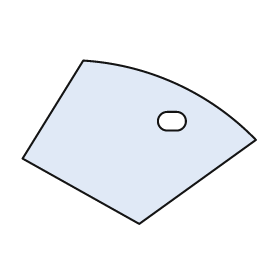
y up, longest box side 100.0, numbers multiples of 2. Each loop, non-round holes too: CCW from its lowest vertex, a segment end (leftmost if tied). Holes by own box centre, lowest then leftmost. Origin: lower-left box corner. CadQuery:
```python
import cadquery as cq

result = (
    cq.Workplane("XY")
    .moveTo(50.0, 0.0)
    .lineTo(100.0, 36.0)
    .threePointArc((66.0, 60.0), (26.0, 70.0))
    .lineTo(0.0, 28.0)
    .close()
    .moveTo(62.0, 40.0)
    .lineTo(66.0, 40.0)
    .threePointArc((70.0, 44.0), (66.0, 48.0))
    .lineTo(62.0, 48.0)
    .threePointArc((58.0, 44.0), (62.0, 40.0))
    .close()
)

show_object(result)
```